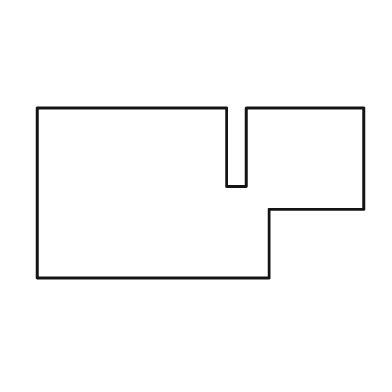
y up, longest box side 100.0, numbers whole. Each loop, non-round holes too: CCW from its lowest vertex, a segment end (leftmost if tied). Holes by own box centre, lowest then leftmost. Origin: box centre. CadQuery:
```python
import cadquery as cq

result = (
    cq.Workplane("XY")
    .moveTo(-50.0, -26.0)
    .lineTo(21.0, -26.0)
    .lineTo(21.0, -5.0)
    .lineTo(50.0, -5.0)
    .lineTo(50.0, 26.0)
    .lineTo(14.0, 26.0)
    .lineTo(14.0, 2.0)
    .lineTo(8.0, 2.0)
    .lineTo(8.0, 26.0)
    .lineTo(-50.0, 26.0)
    .close()
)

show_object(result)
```